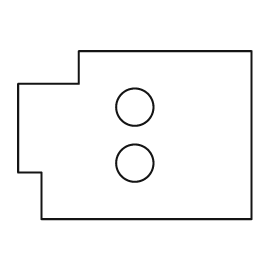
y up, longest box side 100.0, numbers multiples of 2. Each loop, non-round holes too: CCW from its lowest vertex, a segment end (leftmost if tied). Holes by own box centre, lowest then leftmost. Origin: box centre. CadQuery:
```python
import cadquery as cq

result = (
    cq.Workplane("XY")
    .moveTo(-40.0, -36.0)
    .lineTo(50.0, -36.0)
    .lineTo(50.0, 36.0)
    .lineTo(-24.0, 36.0)
    .lineTo(-24.0, 22.0)
    .lineTo(-50.0, 22.0)
    .lineTo(-50.0, -16.0)
    .lineTo(-40.0, -16.0)
    .close()
    .moveTo(0.0, -12.0)
    .circle(8.0)
    .moveTo(0.0, 12.0)
    .circle(8.0)
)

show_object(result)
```